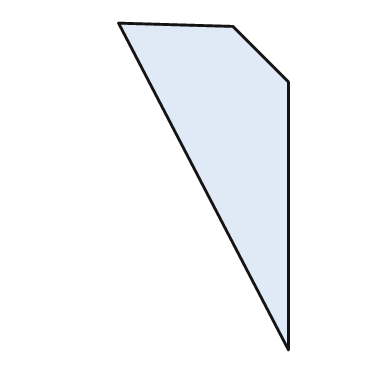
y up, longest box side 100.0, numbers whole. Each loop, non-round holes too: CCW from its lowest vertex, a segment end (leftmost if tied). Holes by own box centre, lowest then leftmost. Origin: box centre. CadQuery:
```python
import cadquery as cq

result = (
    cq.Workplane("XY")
    .moveTo(26.0, -50.0)
    .lineTo(26.0, 32.0)
    .lineTo(9.0, 49.0)
    .lineTo(-26.0, 50.0)
    .close()
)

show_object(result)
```